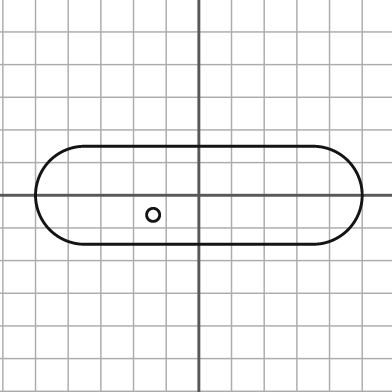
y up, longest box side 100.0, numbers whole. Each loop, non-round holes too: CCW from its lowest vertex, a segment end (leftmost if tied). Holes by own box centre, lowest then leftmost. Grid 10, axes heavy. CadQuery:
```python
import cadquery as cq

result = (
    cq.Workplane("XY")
    .moveTo(-35.0, -15.0)
    .lineTo(35.0, -15.0)
    .threePointArc((50.0, 0.0), (35.0, 15.0))
    .lineTo(-35.0, 15.0)
    .threePointArc((-50.0, 0.0), (-35.0, -15.0))
    .close()
    .moveTo(-14.0, -6.0)
    .circle(2.0)
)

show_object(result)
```